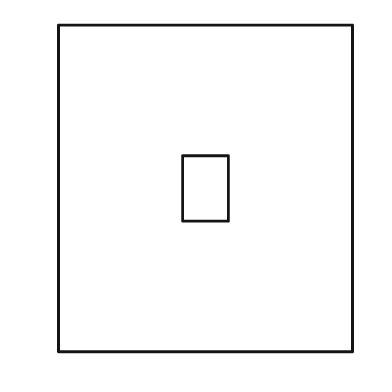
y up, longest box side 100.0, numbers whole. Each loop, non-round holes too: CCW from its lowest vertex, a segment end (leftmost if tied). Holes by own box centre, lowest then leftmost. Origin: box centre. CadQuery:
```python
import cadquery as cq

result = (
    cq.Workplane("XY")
    .moveTo(-45.0, -50.0)
    .lineTo(45.0, -50.0)
    .lineTo(45.0, 50.0)
    .lineTo(-45.0, 50.0)
    .close()
    .moveTo(-7.0, -10.0)
    .lineTo(7.0, -10.0)
    .lineTo(7.0, 10.0)
    .lineTo(-7.0, 10.0)
    .close()
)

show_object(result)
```